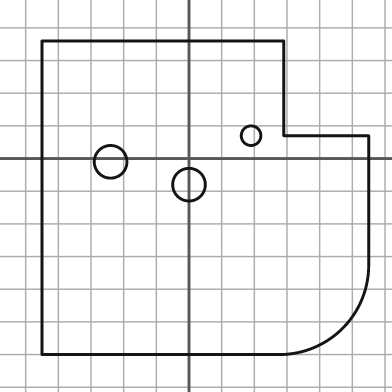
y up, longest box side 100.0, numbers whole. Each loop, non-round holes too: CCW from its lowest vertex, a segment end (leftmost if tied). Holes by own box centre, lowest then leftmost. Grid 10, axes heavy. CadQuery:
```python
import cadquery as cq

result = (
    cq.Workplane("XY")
    .moveTo(-45.0, -60.0)
    .lineTo(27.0, -60.0)
    .threePointArc((47.0, -52.0), (55.0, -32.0))
    .lineTo(55.0, 7.0)
    .lineTo(29.0, 7.0)
    .lineTo(29.0, 36.0)
    .lineTo(-45.0, 36.0)
    .close()
    .moveTo(0.0, -8.0)
    .circle(5.0)
    .moveTo(-24.0, -1.0)
    .circle(5.0)
    .moveTo(19.0, 7.0)
    .circle(3.0)
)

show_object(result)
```